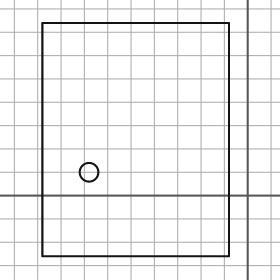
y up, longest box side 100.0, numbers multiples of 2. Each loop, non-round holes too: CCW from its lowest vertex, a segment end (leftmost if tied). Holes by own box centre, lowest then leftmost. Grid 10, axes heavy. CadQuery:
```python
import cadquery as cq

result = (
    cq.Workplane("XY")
    .moveTo(-88.0, -26.0)
    .lineTo(-8.0, -26.0)
    .lineTo(-8.0, 74.0)
    .lineTo(-88.0, 74.0)
    .close()
    .moveTo(-68.0, 10.0)
    .circle(4.0)
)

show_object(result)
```